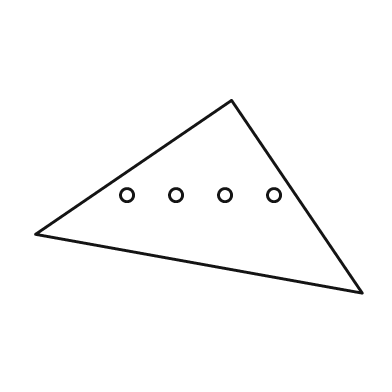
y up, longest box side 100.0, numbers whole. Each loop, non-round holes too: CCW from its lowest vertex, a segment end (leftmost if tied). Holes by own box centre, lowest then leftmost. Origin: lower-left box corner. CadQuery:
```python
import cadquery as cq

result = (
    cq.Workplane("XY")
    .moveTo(100.0, 0.0)
    .lineTo(60.0, 59.0)
    .lineTo(0.0, 18.0)
    .close()
    .moveTo(28.0, 30.0)
    .circle(2.0)
    .moveTo(43.0, 30.0)
    .circle(2.0)
    .moveTo(58.0, 30.0)
    .circle(2.0)
    .moveTo(73.0, 30.0)
    .circle(2.0)
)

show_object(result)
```